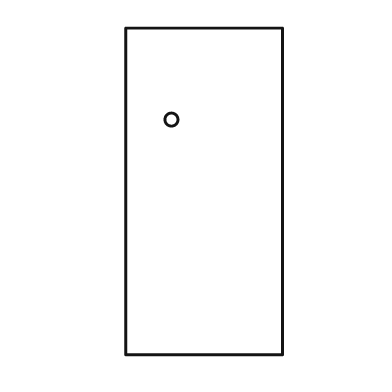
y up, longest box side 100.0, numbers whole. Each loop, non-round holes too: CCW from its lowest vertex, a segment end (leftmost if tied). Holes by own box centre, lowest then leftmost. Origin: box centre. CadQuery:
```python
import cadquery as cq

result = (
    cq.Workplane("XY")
    .moveTo(-24.0, -50.0)
    .lineTo(24.0, -50.0)
    .lineTo(24.0, 50.0)
    .lineTo(-24.0, 50.0)
    .close()
    .moveTo(-10.0, 22.0)
    .circle(2.0)
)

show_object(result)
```